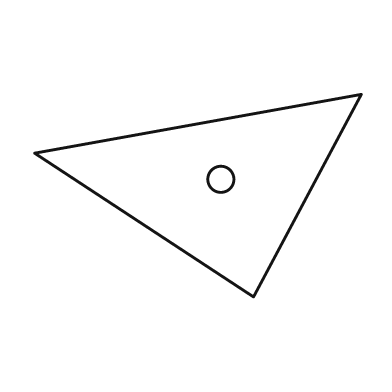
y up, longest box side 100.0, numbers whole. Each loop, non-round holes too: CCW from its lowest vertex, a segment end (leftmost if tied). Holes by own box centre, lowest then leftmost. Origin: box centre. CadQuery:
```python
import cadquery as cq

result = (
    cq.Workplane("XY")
    .moveTo(17.0, -31.0)
    .lineTo(50.0, 31.0)
    .lineTo(-50.0, 13.0)
    .close()
    .moveTo(7.0, 5.0)
    .circle(4.0)
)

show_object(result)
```